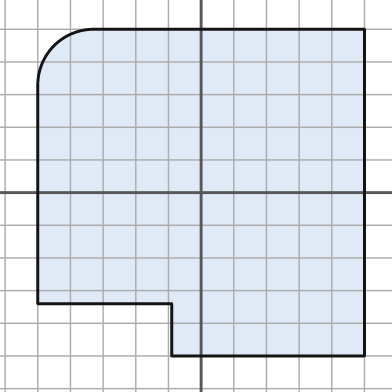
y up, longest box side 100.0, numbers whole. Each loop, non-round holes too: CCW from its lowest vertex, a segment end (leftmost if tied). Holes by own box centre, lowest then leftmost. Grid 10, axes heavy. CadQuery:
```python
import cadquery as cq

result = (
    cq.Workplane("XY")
    .moveTo(-9.0, -50.0)
    .lineTo(50.0, -50.0)
    .lineTo(50.0, 50.0)
    .lineTo(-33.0, 50.0)
    .threePointArc((-45.0, 45.0), (-50.0, 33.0))
    .lineTo(-50.0, -34.0)
    .lineTo(-9.0, -34.0)
    .close()
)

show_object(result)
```